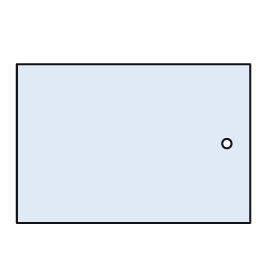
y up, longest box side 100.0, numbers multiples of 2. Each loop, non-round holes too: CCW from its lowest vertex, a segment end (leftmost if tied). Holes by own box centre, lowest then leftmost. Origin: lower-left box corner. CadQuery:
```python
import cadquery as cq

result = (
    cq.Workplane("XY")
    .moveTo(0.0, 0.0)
    .lineTo(100.0, 0.0)
    .lineTo(100.0, 68.0)
    .lineTo(0.0, 68.0)
    .close()
    .moveTo(90.0, 34.0)
    .circle(2.0)
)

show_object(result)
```